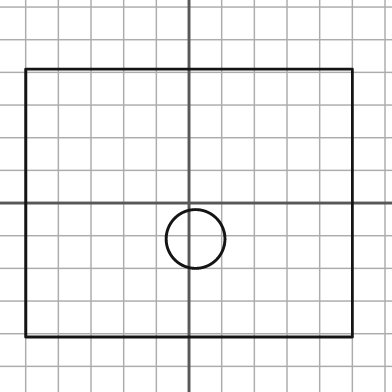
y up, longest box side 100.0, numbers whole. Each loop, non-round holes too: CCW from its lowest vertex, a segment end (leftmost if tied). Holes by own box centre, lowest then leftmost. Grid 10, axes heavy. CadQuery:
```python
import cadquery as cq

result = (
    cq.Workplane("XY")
    .moveTo(-50.0, -41.0)
    .lineTo(50.0, -41.0)
    .lineTo(50.0, 41.0)
    .lineTo(-50.0, 41.0)
    .close()
    .moveTo(2.0, -11.0)
    .circle(9.0)
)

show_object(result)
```